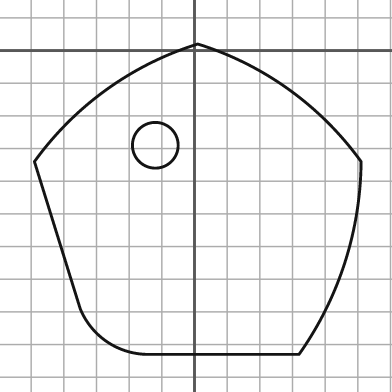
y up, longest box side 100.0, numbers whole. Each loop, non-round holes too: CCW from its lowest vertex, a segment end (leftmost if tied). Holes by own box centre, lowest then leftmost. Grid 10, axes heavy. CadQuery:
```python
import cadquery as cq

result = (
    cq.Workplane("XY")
    .moveTo(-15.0, -93.0)
    .lineTo(32.0, -93.0)
    .threePointArc((46.0, -65.0), (51.0, -34.0))
    .threePointArc((29.0, -12.0), (1.0, 2.0))
    .threePointArc((-27.0, -12.0), (-49.0, -34.0))
    .lineTo(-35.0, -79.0)
    .threePointArc((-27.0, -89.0), (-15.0, -93.0))
    .close()
    .moveTo(-12.0, -29.0)
    .circle(7.0)
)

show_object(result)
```